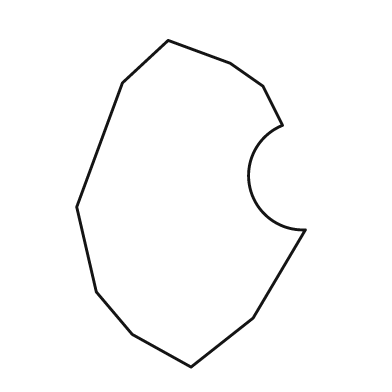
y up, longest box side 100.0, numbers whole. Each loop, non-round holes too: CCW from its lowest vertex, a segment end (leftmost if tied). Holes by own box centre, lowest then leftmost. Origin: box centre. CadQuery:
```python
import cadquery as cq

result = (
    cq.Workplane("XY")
    .moveTo(0.0, -50.0)
    .lineTo(19.0, -35.0)
    .lineTo(35.0, -8.0)
    .threePointArc((18.0, 5.0), (28.0, 24.0))
    .lineTo(22.0, 36.0)
    .lineTo(12.0, 43.0)
    .lineTo(-7.0, 50.0)
    .lineTo(-21.0, 37.0)
    .lineTo(-35.0, -1.0)
    .lineTo(-29.0, -27.0)
    .lineTo(-18.0, -40.0)
    .close()
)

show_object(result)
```